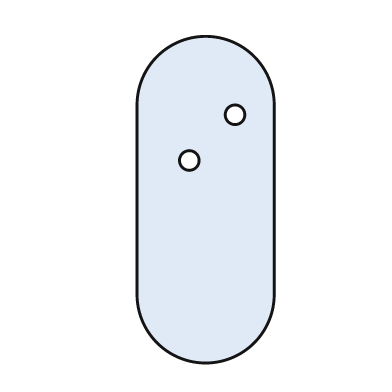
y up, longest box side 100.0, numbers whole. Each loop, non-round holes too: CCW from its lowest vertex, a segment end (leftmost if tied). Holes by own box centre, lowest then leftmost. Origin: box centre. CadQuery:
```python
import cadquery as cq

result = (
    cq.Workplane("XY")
    .moveTo(-21.0, -29.0)
    .threePointArc((0.0, -50.0), (21.0, -29.0))
    .lineTo(21.0, 29.0)
    .threePointArc((0.0, 50.0), (-21.0, 29.0))
    .close()
    .moveTo(-5.0, 12.0)
    .circle(3.0)
    .moveTo(9.0, 26.0)
    .circle(3.0)
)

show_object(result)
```